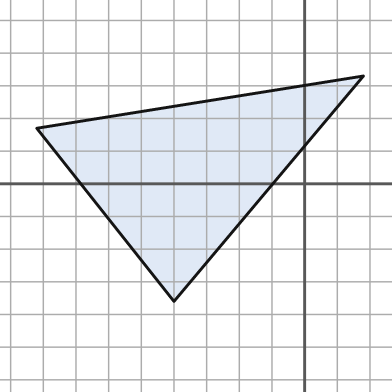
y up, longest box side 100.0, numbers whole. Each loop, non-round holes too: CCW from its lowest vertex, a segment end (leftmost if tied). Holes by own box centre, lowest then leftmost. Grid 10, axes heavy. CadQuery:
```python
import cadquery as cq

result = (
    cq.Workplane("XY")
    .moveTo(-40.0, -36.0)
    .lineTo(18.0, 33.0)
    .lineTo(-82.0, 17.0)
    .close()
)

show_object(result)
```